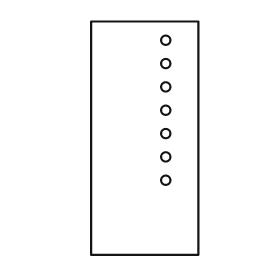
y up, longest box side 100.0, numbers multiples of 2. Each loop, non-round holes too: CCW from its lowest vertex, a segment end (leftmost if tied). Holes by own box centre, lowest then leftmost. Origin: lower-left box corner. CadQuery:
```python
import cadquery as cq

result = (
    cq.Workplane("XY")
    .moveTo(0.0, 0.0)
    .lineTo(46.0, 0.0)
    .lineTo(46.0, 100.0)
    .lineTo(0.0, 100.0)
    .close()
    .moveTo(32.0, 32.0)
    .circle(2.0)
    .moveTo(32.0, 42.0)
    .circle(2.0)
    .moveTo(32.0, 52.0)
    .circle(2.0)
    .moveTo(32.0, 62.0)
    .circle(2.0)
    .moveTo(32.0, 72.0)
    .circle(2.0)
    .moveTo(32.0, 82.0)
    .circle(2.0)
    .moveTo(32.0, 92.0)
    .circle(2.0)
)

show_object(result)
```